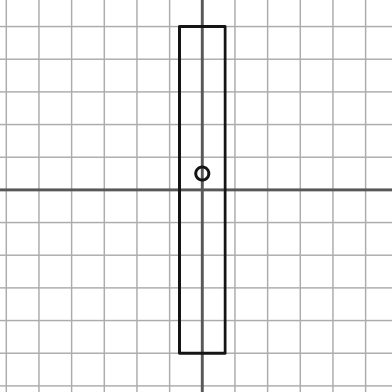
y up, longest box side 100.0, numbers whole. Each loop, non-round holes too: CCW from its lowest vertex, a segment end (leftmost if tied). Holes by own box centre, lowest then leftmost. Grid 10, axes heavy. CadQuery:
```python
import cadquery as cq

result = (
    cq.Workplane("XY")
    .moveTo(-7.0, -50.0)
    .lineTo(7.0, -50.0)
    .lineTo(7.0, 50.0)
    .lineTo(-7.0, 50.0)
    .close()
    .moveTo(0.0, 5.0)
    .circle(2.0)
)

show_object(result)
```